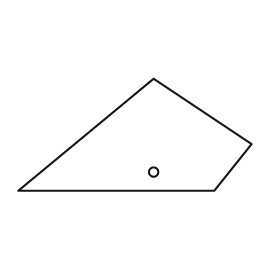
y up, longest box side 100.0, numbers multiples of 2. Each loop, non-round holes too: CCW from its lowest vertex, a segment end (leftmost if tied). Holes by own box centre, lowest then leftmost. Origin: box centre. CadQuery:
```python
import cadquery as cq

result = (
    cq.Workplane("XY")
    .moveTo(-50.0, -24.0)
    .lineTo(34.0, -24.0)
    .lineTo(50.0, -4.0)
    .lineTo(8.0, 24.0)
    .close()
    .moveTo(8.0, -16.0)
    .circle(2.0)
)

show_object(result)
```